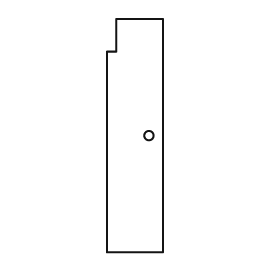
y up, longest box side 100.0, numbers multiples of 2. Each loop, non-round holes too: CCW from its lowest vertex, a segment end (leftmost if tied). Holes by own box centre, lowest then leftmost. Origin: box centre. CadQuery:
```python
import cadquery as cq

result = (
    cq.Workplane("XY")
    .moveTo(-12.0, -50.0)
    .lineTo(12.0, -50.0)
    .lineTo(12.0, 50.0)
    .lineTo(-8.0, 50.0)
    .lineTo(-8.0, 36.0)
    .lineTo(-12.0, 36.0)
    .close()
    .moveTo(6.0, 0.0)
    .circle(2.0)
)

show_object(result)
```